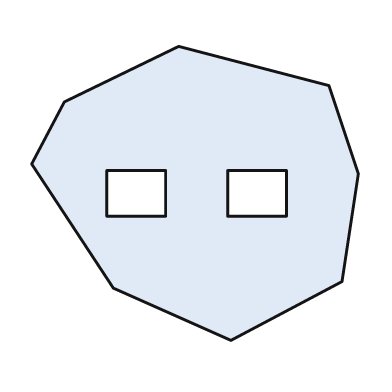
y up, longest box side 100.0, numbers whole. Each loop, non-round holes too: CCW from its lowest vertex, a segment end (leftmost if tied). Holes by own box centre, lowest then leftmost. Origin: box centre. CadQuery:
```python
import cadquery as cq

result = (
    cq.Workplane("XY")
    .moveTo(11.0, -45.0)
    .lineTo(45.0, -27.0)
    .lineTo(50.0, 6.0)
    .lineTo(41.0, 33.0)
    .lineTo(-5.0, 45.0)
    .lineTo(-40.0, 28.0)
    .lineTo(-50.0, 9.0)
    .lineTo(-25.0, -29.0)
    .close()
    .moveTo(-27.0, -7.0)
    .lineTo(-9.0, -7.0)
    .lineTo(-9.0, 7.0)
    .lineTo(-27.0, 7.0)
    .close()
    .moveTo(10.0, -7.0)
    .lineTo(28.0, -7.0)
    .lineTo(28.0, 7.0)
    .lineTo(10.0, 7.0)
    .close()
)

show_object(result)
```